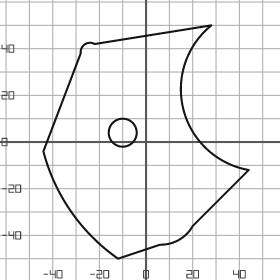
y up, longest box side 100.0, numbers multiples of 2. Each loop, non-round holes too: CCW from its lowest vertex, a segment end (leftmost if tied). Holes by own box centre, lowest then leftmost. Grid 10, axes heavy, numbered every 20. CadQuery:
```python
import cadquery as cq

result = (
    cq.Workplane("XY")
    .moveTo(-12.0, -50.0)
    .lineTo(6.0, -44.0)
    .threePointArc((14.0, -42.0), (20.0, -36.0))
    .lineTo(44.0, -12.0)
    .threePointArc((16.0, 14.0), (28.0, 50.0))
    .lineTo(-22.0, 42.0)
    .threePointArc((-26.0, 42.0), (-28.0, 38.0))
    .lineTo(-44.0, -4.0)
    .threePointArc((-32.0, -30.0), (-12.0, -50.0))
    .close()
    .moveTo(-10.0, 4.0)
    .circle(6.0)
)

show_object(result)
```